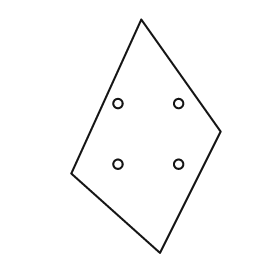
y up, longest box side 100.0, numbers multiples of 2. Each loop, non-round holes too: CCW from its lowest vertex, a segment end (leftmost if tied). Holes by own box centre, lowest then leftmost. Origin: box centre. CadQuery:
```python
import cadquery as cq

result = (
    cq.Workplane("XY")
    .moveTo(6.0, -50.0)
    .lineTo(32.0, 2.0)
    .lineTo(-2.0, 50.0)
    .lineTo(-32.0, -16.0)
    .close()
    .moveTo(-12.0, -12.0)
    .circle(2.0)
    .moveTo(14.0, -12.0)
    .circle(2.0)
    .moveTo(-12.0, 14.0)
    .circle(2.0)
    .moveTo(14.0, 14.0)
    .circle(2.0)
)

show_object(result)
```